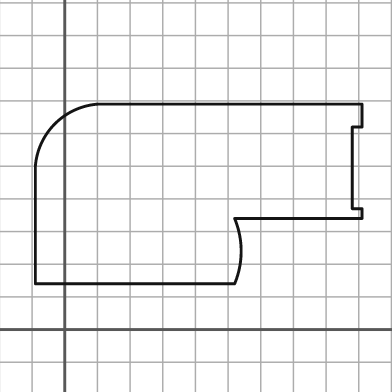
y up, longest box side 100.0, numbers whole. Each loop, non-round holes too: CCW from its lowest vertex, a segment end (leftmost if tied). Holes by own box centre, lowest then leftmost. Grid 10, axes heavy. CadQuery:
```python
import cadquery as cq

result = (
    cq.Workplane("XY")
    .moveTo(-9.0, 14.0)
    .lineTo(52.0, 14.0)
    .threePointArc((54.0, 24.0), (52.0, 34.0))
    .lineTo(91.0, 34.0)
    .lineTo(91.0, 37.0)
    .lineTo(88.0, 37.0)
    .lineTo(88.0, 62.0)
    .lineTo(91.0, 62.0)
    .lineTo(91.0, 69.0)
    .lineTo(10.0, 69.0)
    .threePointArc((-3.0, 63.0), (-9.0, 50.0))
    .close()
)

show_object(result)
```